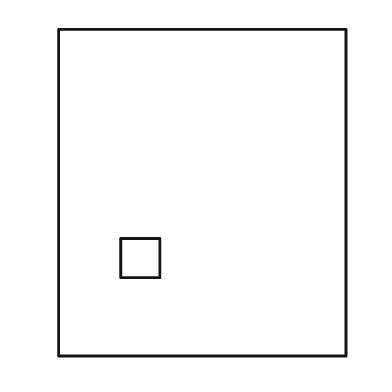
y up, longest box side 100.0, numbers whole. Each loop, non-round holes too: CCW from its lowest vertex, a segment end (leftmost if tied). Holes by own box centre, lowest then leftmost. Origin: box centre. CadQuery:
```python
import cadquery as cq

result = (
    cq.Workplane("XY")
    .moveTo(-44.0, -50.0)
    .lineTo(44.0, -50.0)
    .lineTo(44.0, 50.0)
    .lineTo(-44.0, 50.0)
    .close()
    .moveTo(-25.0, -26.0)
    .lineTo(-13.0, -26.0)
    .lineTo(-13.0, -14.0)
    .lineTo(-25.0, -14.0)
    .close()
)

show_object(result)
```